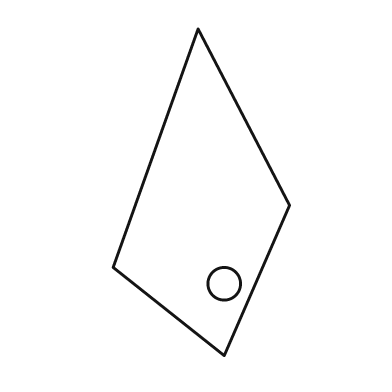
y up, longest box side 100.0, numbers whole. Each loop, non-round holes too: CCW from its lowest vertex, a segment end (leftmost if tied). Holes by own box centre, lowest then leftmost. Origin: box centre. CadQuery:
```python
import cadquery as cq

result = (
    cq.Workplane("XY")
    .moveTo(7.0, -50.0)
    .lineTo(27.0, -4.0)
    .lineTo(-1.0, 50.0)
    .lineTo(-27.0, -23.0)
    .close()
    .moveTo(7.0, -28.0)
    .circle(5.0)
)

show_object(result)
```